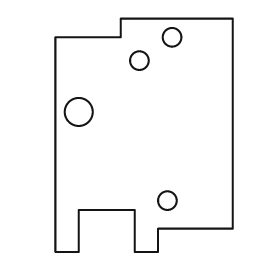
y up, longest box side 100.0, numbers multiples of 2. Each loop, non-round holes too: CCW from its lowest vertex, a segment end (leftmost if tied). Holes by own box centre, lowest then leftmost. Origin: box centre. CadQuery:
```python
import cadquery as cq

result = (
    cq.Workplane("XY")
    .moveTo(-38.0, -50.0)
    .lineTo(-28.0, -50.0)
    .lineTo(-28.0, -32.0)
    .lineTo(-4.0, -32.0)
    .lineTo(-4.0, -50.0)
    .lineTo(6.0, -50.0)
    .lineTo(6.0, -40.0)
    .lineTo(38.0, -40.0)
    .lineTo(38.0, 50.0)
    .lineTo(-10.0, 50.0)
    .lineTo(-10.0, 42.0)
    .lineTo(-38.0, 42.0)
    .close()
    .moveTo(10.0, -28.0)
    .circle(4.0)
    .moveTo(-28.0, 10.0)
    .circle(6.0)
    .moveTo(-2.0, 32.0)
    .circle(4.0)
    .moveTo(12.0, 42.0)
    .circle(4.0)
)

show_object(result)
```